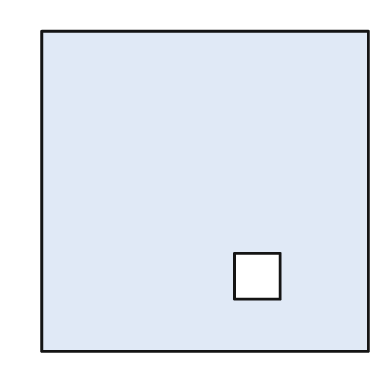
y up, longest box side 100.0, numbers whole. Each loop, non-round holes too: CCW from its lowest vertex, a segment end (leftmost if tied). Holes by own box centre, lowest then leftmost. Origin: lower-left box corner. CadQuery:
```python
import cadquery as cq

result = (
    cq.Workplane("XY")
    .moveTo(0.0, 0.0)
    .lineTo(100.0, 0.0)
    .lineTo(100.0, 98.0)
    .lineTo(0.0, 98.0)
    .close()
    .moveTo(59.0, 16.0)
    .lineTo(73.0, 16.0)
    .lineTo(73.0, 30.0)
    .lineTo(59.0, 30.0)
    .close()
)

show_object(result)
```